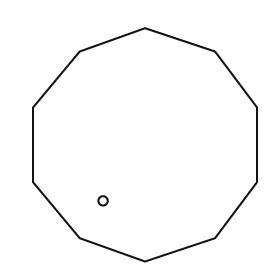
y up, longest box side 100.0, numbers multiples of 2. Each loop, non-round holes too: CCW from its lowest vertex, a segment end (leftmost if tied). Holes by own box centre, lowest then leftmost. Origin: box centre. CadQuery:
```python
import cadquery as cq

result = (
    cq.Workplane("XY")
    .moveTo(0.0, -50.0)
    .lineTo(30.0, -40.0)
    .lineTo(48.0, -16.0)
    .lineTo(48.0, 16.0)
    .lineTo(30.0, 40.0)
    .lineTo(0.0, 50.0)
    .lineTo(-28.0, 40.0)
    .lineTo(-48.0, 16.0)
    .lineTo(-48.0, -16.0)
    .lineTo(-28.0, -40.0)
    .close()
    .moveTo(-18.0, -24.0)
    .circle(2.0)
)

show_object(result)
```